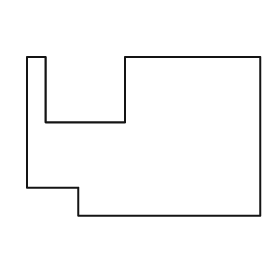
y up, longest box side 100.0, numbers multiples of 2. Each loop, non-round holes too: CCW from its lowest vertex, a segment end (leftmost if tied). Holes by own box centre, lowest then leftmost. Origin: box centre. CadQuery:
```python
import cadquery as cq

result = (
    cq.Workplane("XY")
    .moveTo(-28.0, -34.0)
    .lineTo(50.0, -34.0)
    .lineTo(50.0, 34.0)
    .lineTo(-8.0, 34.0)
    .lineTo(-8.0, 6.0)
    .lineTo(-42.0, 6.0)
    .lineTo(-42.0, 34.0)
    .lineTo(-50.0, 34.0)
    .lineTo(-50.0, -22.0)
    .lineTo(-28.0, -22.0)
    .close()
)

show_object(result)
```